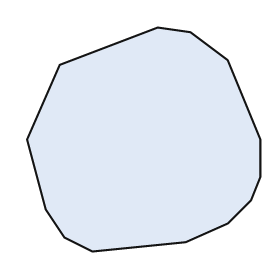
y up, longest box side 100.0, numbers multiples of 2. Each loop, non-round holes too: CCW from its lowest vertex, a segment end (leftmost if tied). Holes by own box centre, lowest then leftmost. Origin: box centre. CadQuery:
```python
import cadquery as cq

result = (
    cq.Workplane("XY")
    .moveTo(-22.0, -48.0)
    .lineTo(18.0, -44.0)
    .lineTo(36.0, -36.0)
    .lineTo(46.0, -26.0)
    .lineTo(50.0, -16.0)
    .lineTo(50.0, 0.0)
    .lineTo(36.0, 34.0)
    .lineTo(20.0, 46.0)
    .lineTo(6.0, 48.0)
    .lineTo(-36.0, 32.0)
    .lineTo(-50.0, 0.0)
    .lineTo(-42.0, -30.0)
    .lineTo(-34.0, -42.0)
    .close()
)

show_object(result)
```